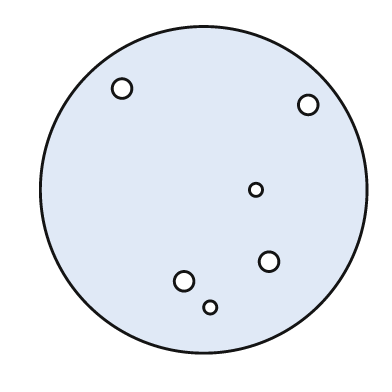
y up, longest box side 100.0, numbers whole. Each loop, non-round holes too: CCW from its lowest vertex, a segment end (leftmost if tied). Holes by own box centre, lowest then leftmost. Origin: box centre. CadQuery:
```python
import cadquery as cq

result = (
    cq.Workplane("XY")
    .moveTo(0.0, 0.0)
    .circle(50.0)
    .moveTo(2.0, -36.0)
    .circle(2.0)
    .moveTo(-6.0, -28.0)
    .circle(3.0)
    .moveTo(20.0, -22.0)
    .circle(3.0)
    .moveTo(16.0, 0.0)
    .circle(2.0)
    .moveTo(32.0, 26.0)
    .circle(3.0)
    .moveTo(-25.0, 31.0)
    .circle(3.0)
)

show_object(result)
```